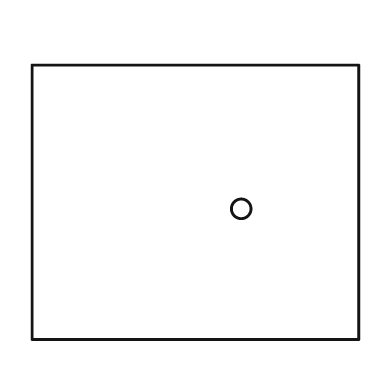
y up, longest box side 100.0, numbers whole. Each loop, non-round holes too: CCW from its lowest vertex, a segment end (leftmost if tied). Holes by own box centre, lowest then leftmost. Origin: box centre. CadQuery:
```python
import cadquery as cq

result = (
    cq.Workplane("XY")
    .moveTo(-50.0, -42.0)
    .lineTo(50.0, -42.0)
    .lineTo(50.0, 42.0)
    .lineTo(-50.0, 42.0)
    .close()
    .moveTo(14.0, -2.0)
    .circle(3.0)
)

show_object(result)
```